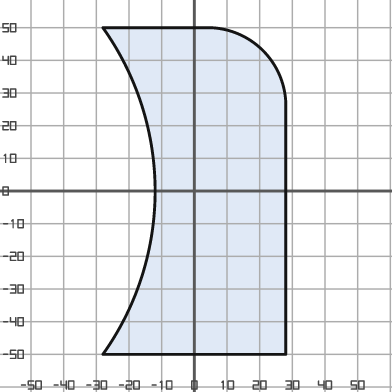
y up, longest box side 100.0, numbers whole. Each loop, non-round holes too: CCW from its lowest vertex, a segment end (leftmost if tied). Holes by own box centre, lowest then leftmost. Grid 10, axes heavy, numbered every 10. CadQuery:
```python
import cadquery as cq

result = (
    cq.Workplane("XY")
    .moveTo(-28.0, -50.0)
    .lineTo(28.0, -50.0)
    .lineTo(28.0, 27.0)
    .threePointArc((21.0, 43.0), (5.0, 50.0))
    .lineTo(-28.0, 50.0)
    .threePointArc((-12.0, 0.0), (-28.0, -50.0))
    .close()
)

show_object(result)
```